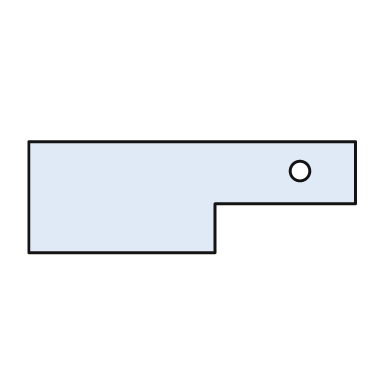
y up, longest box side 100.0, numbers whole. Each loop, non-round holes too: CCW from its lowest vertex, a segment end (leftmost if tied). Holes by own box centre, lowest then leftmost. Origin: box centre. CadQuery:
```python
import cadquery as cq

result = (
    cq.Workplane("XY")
    .moveTo(-50.0, -17.0)
    .lineTo(7.0, -17.0)
    .lineTo(7.0, -2.0)
    .lineTo(50.0, -2.0)
    .lineTo(50.0, 17.0)
    .lineTo(-50.0, 17.0)
    .close()
    .moveTo(33.0, 8.0)
    .circle(3.0)
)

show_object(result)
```